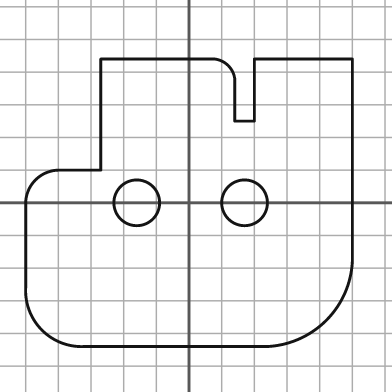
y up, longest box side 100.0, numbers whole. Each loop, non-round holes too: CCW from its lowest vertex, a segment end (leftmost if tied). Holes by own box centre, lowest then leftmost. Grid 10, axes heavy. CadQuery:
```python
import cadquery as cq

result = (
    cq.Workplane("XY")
    .moveTo(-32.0, -44.0)
    .lineTo(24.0, -44.0)
    .threePointArc((42.0, -36.0), (50.0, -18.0))
    .lineTo(50.0, 44.0)
    .lineTo(20.0, 44.0)
    .lineTo(20.0, 25.0)
    .lineTo(14.0, 25.0)
    .lineTo(14.0, 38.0)
    .threePointArc((12.0, 42.0), (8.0, 44.0))
    .lineTo(-27.0, 44.0)
    .lineTo(-27.0, 10.0)
    .lineTo(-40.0, 10.0)
    .threePointArc((-47.0, 7.0), (-50.0, 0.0))
    .lineTo(-50.0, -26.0)
    .threePointArc((-45.0, -39.0), (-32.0, -44.0))
    .close()
    .moveTo(-16.0, 0.0)
    .circle(7.0)
    .moveTo(17.0, 0.0)
    .circle(7.0)
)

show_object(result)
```